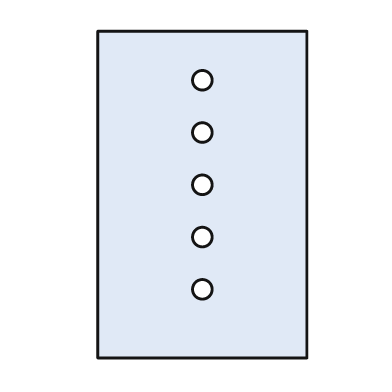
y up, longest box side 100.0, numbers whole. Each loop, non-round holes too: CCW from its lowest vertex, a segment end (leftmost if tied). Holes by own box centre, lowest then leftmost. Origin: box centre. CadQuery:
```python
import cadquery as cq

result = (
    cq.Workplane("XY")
    .moveTo(-32.0, -50.0)
    .lineTo(32.0, -50.0)
    .lineTo(32.0, 50.0)
    .lineTo(-32.0, 50.0)
    .close()
    .moveTo(0.0, -29.0)
    .circle(3.0)
    .moveTo(0.0, -13.0)
    .circle(3.0)
    .moveTo(0.0, 3.0)
    .circle(3.0)
    .moveTo(0.0, 19.0)
    .circle(3.0)
    .moveTo(0.0, 35.0)
    .circle(3.0)
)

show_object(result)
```